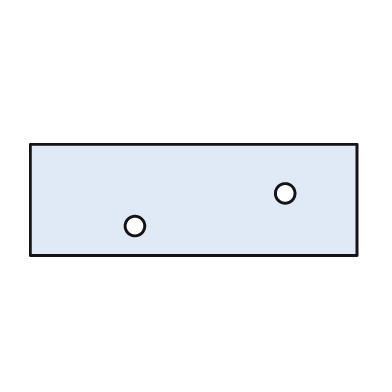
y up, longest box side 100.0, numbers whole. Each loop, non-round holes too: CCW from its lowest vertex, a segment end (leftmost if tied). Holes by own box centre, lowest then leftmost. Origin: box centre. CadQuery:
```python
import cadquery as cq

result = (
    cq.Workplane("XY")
    .moveTo(-50.0, -17.0)
    .lineTo(50.0, -17.0)
    .lineTo(50.0, 17.0)
    .lineTo(-50.0, 17.0)
    .close()
    .moveTo(-18.0, -8.0)
    .circle(3.0)
    .moveTo(28.0, 2.0)
    .circle(3.0)
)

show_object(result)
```